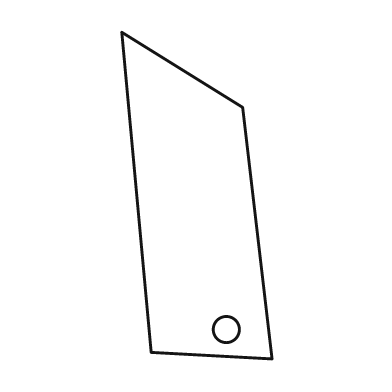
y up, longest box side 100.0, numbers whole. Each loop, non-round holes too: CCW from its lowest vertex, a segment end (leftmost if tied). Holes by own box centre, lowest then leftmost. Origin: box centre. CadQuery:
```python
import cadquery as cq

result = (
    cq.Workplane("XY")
    .moveTo(23.0, -50.0)
    .lineTo(14.0, 27.0)
    .lineTo(-23.0, 50.0)
    .lineTo(-14.0, -48.0)
    .close()
    .moveTo(9.0, -41.0)
    .circle(4.0)
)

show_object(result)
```